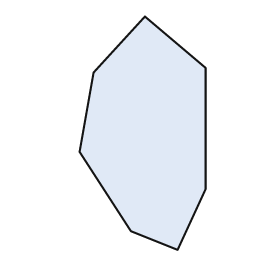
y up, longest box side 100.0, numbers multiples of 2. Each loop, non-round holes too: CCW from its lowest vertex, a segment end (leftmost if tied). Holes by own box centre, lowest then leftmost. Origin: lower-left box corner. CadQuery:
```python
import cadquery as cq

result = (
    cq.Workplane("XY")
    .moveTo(42.0, 0.0)
    .lineTo(54.0, 26.0)
    .lineTo(54.0, 78.0)
    .lineTo(28.0, 100.0)
    .lineTo(6.0, 76.0)
    .lineTo(0.0, 42.0)
    .lineTo(22.0, 8.0)
    .close()
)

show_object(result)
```